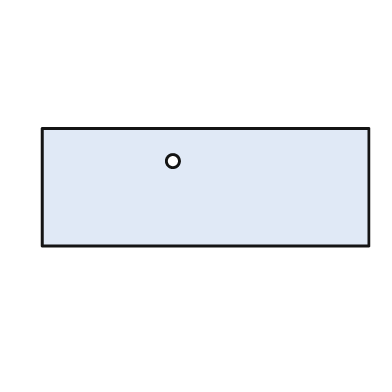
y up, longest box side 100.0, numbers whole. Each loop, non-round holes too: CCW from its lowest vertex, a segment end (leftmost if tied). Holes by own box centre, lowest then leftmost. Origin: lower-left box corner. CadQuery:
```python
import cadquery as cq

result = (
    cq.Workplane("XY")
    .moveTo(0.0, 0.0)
    .lineTo(100.0, 0.0)
    .lineTo(100.0, 36.0)
    .lineTo(0.0, 36.0)
    .close()
    .moveTo(40.0, 26.0)
    .circle(2.0)
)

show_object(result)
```